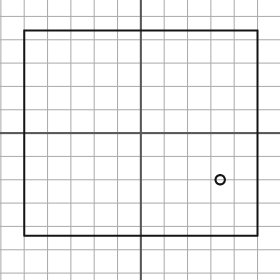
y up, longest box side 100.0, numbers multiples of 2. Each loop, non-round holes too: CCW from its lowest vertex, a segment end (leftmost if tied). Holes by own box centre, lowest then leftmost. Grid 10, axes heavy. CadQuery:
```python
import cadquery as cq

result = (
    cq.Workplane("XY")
    .moveTo(-50.0, -44.0)
    .lineTo(50.0, -44.0)
    .lineTo(50.0, 44.0)
    .lineTo(-50.0, 44.0)
    .close()
    .moveTo(34.0, -20.0)
    .circle(2.0)
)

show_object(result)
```